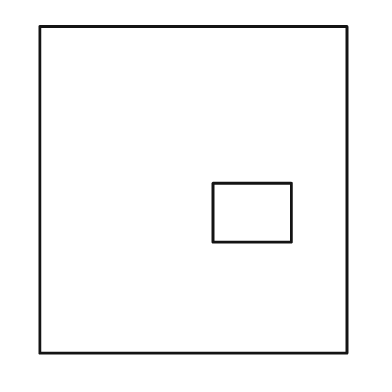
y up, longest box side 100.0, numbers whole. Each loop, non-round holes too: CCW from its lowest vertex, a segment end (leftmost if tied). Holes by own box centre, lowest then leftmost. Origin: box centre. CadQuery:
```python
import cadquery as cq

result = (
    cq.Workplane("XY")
    .moveTo(-47.0, -50.0)
    .lineTo(47.0, -50.0)
    .lineTo(47.0, 50.0)
    .lineTo(-47.0, 50.0)
    .close()
    .moveTo(6.0, -16.0)
    .lineTo(30.0, -16.0)
    .lineTo(30.0, 2.0)
    .lineTo(6.0, 2.0)
    .close()
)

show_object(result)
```